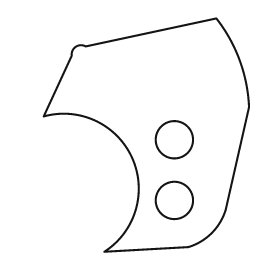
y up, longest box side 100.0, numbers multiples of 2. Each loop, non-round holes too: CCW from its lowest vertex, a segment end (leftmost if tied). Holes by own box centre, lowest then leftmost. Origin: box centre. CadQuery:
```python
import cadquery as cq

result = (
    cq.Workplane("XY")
    .moveTo(-18.0, -50.0)
    .lineTo(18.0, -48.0)
    .threePointArc((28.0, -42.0), (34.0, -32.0))
    .lineTo(44.0, 12.0)
    .threePointArc((40.0, 32.0), (30.0, 50.0))
    .lineTo(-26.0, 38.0)
    .threePointArc((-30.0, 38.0), (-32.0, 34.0))
    .lineTo(-44.0, 8.0)
    .threePointArc((-6.0, -10.0), (-18.0, -50.0))
    .close()
    .moveTo(12.0, -28.0)
    .circle(8.0)
    .moveTo(12.0, -2.0)
    .circle(8.0)
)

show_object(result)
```